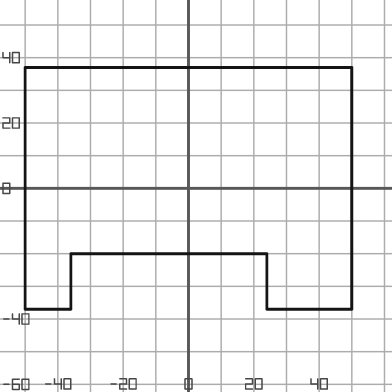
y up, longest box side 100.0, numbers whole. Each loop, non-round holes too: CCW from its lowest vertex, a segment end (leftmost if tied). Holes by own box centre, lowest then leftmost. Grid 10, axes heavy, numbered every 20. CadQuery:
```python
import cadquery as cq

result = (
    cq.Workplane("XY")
    .moveTo(-50.0, -37.0)
    .lineTo(-36.0, -37.0)
    .lineTo(-36.0, -20.0)
    .lineTo(24.0, -20.0)
    .lineTo(24.0, -37.0)
    .lineTo(50.0, -37.0)
    .lineTo(50.0, 37.0)
    .lineTo(-50.0, 37.0)
    .close()
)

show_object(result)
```